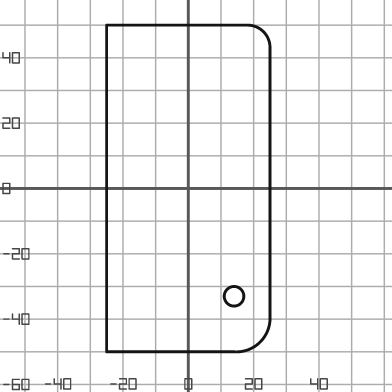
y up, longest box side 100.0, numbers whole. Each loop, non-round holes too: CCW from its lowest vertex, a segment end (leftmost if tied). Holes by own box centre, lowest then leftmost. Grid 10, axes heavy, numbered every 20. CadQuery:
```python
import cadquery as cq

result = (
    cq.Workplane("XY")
    .moveTo(-25.0, -50.0)
    .lineTo(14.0, -50.0)
    .threePointArc((22.0, -47.0), (25.0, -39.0))
    .lineTo(25.0, 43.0)
    .threePointArc((23.0, 48.0), (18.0, 50.0))
    .lineTo(-25.0, 50.0)
    .close()
    .moveTo(14.0, -33.0)
    .circle(3.0)
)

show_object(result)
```